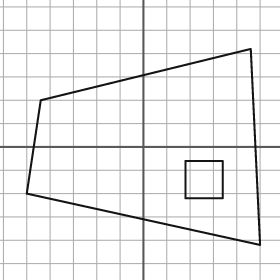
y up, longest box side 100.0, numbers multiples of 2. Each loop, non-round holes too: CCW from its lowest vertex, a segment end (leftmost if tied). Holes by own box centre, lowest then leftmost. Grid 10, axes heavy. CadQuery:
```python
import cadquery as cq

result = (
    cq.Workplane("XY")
    .moveTo(50.0, -42.0)
    .lineTo(46.0, 42.0)
    .lineTo(-44.0, 20.0)
    .lineTo(-50.0, -20.0)
    .close()
    .moveTo(18.0, -22.0)
    .lineTo(34.0, -22.0)
    .lineTo(34.0, -6.0)
    .lineTo(18.0, -6.0)
    .close()
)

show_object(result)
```